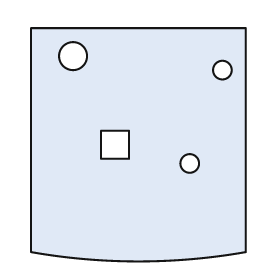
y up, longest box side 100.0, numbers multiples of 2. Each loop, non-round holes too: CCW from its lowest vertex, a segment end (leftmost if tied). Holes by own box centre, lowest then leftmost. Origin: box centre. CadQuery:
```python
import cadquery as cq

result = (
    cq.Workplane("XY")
    .moveTo(-46.0, -46.0)
    .threePointArc((0.0, -50.0), (46.0, -46.0))
    .lineTo(46.0, 50.0)
    .lineTo(-46.0, 50.0)
    .close()
    .moveTo(22.0, -8.0)
    .circle(4.0)
    .moveTo(-16.0, -6.0)
    .lineTo(-4.0, -6.0)
    .lineTo(-4.0, 6.0)
    .lineTo(-16.0, 6.0)
    .close()
    .moveTo(36.0, 32.0)
    .circle(4.0)
    .moveTo(-28.0, 38.0)
    .circle(6.0)
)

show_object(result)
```